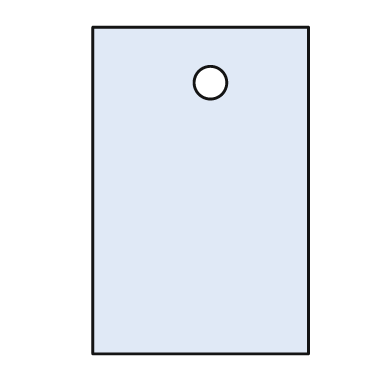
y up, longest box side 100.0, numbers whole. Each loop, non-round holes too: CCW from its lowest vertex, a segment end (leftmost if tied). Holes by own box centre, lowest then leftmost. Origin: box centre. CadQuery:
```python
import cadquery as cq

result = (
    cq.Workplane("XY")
    .moveTo(-33.0, -50.0)
    .lineTo(33.0, -50.0)
    .lineTo(33.0, 50.0)
    .lineTo(-33.0, 50.0)
    .close()
    .moveTo(3.0, 33.0)
    .circle(5.0)
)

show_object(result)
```